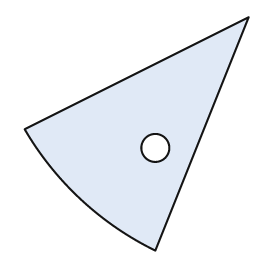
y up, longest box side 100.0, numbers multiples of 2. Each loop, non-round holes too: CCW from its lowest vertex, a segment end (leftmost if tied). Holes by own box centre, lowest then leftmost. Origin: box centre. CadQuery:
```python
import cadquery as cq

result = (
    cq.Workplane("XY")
    .moveTo(8.0, -50.0)
    .lineTo(48.0, 50.0)
    .lineTo(-48.0, 2.0)
    .threePointArc((-24.0, -28.0), (8.0, -50.0))
    .close()
    .moveTo(8.0, -6.0)
    .circle(6.0)
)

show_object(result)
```